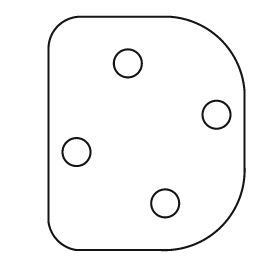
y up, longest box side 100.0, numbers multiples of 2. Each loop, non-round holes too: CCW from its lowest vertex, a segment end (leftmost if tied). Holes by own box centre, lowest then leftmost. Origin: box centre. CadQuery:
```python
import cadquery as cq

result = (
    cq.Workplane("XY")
    .moveTo(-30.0, -50.0)
    .lineTo(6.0, -50.0)
    .threePointArc((32.0, -40.0), (42.0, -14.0))
    .lineTo(42.0, 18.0)
    .threePointArc((32.0, 40.0), (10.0, 50.0))
    .lineTo(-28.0, 50.0)
    .threePointArc((-38.0, 46.0), (-42.0, 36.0))
    .lineTo(-42.0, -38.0)
    .threePointArc((-38.0, -46.0), (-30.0, -50.0))
    .close()
    .moveTo(8.0, -30.0)
    .circle(6.0)
    .moveTo(-30.0, -8.0)
    .circle(6.0)
    .moveTo(30.0, 8.0)
    .circle(6.0)
    .moveTo(-8.0, 30.0)
    .circle(6.0)
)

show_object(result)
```